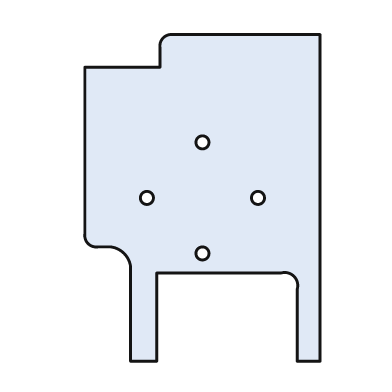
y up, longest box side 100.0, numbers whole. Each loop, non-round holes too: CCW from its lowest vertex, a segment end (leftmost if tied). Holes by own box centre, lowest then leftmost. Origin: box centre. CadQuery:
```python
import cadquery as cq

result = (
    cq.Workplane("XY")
    .moveTo(-22.0, -50.0)
    .lineTo(-14.0, -50.0)
    .lineTo(-14.0, -23.0)
    .lineTo(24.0, -23.0)
    .threePointArc((28.0, -24.0), (29.0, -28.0))
    .lineTo(29.0, -50.0)
    .lineTo(36.0, -50.0)
    .lineTo(36.0, 50.0)
    .lineTo(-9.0, 50.0)
    .threePointArc((-12.0, 49.0), (-13.0, 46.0))
    .lineTo(-13.0, 40.0)
    .lineTo(-36.0, 40.0)
    .lineTo(-36.0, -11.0)
    .threePointArc((-35.0, -14.0), (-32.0, -15.0))
    .lineTo(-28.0, -15.0)
    .threePointArc((-24.0, -17.0), (-22.0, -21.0))
    .close()
    .moveTo(0.0, -17.0)
    .circle(2.0)
    .moveTo(-17.0, 0.0)
    .circle(2.0)
    .moveTo(17.0, 0.0)
    .circle(2.0)
    .moveTo(0.0, 17.0)
    .circle(2.0)
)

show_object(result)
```